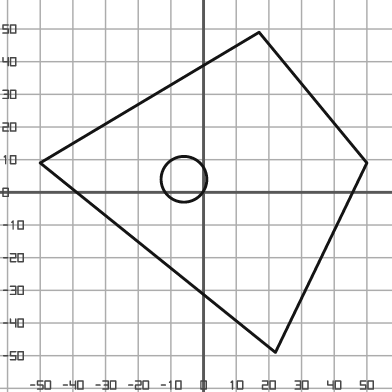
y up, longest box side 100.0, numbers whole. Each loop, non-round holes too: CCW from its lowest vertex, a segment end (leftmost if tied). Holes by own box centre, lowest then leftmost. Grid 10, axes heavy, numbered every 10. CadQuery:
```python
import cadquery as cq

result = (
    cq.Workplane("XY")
    .moveTo(22.0, -49.0)
    .lineTo(50.0, 9.0)
    .lineTo(17.0, 49.0)
    .lineTo(-50.0, 9.0)
    .close()
    .moveTo(-6.0, 4.0)
    .circle(7.0)
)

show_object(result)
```